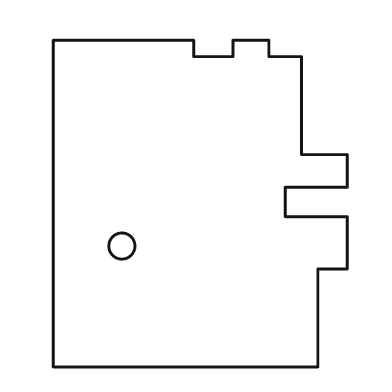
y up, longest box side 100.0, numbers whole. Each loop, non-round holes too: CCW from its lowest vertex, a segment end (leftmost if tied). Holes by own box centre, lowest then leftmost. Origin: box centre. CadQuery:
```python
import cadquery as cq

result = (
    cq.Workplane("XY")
    .moveTo(-45.0, -50.0)
    .lineTo(36.0, -50.0)
    .lineTo(36.0, -20.0)
    .lineTo(45.0, -20.0)
    .lineTo(45.0, -4.0)
    .lineTo(26.0, -4.0)
    .lineTo(26.0, 5.0)
    .lineTo(45.0, 5.0)
    .lineTo(45.0, 15.0)
    .lineTo(31.0, 15.0)
    .lineTo(31.0, 45.0)
    .lineTo(21.0, 45.0)
    .lineTo(21.0, 50.0)
    .lineTo(10.0, 50.0)
    .lineTo(10.0, 45.0)
    .lineTo(-2.0, 45.0)
    .lineTo(-2.0, 50.0)
    .lineTo(-45.0, 50.0)
    .close()
    .moveTo(-24.0, -13.0)
    .circle(4.0)
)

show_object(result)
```